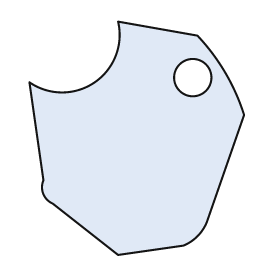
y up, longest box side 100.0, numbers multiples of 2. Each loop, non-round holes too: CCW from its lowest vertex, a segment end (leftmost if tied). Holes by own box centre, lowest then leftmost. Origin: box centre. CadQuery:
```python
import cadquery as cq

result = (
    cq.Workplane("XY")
    .moveTo(-8.0, -50.0)
    .lineTo(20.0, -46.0)
    .threePointArc((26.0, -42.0), (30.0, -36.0))
    .lineTo(46.0, 10.0)
    .threePointArc((38.0, 28.0), (26.0, 44.0))
    .lineTo(-8.0, 50.0)
    .threePointArc((-18.0, 24.0), (-46.0, 24.0))
    .lineTo(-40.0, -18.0)
    .threePointArc((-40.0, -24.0), (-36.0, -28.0))
    .close()
    .moveTo(24.0, 26.0)
    .circle(8.0)
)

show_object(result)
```